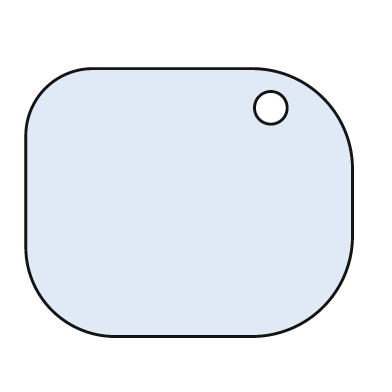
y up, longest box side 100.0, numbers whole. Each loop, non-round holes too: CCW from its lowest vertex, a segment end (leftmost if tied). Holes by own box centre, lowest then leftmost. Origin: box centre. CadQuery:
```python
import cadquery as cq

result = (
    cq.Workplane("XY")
    .moveTo(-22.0, -41.0)
    .lineTo(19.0, -41.0)
    .threePointArc((41.0, -32.0), (50.0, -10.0))
    .lineTo(50.0, 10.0)
    .threePointArc((41.0, 32.0), (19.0, 41.0))
    .lineTo(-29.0, 41.0)
    .threePointArc((-44.0, 35.0), (-50.0, 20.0))
    .lineTo(-50.0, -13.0)
    .threePointArc((-42.0, -33.0), (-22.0, -41.0))
    .close()
    .moveTo(25.0, 29.0)
    .circle(5.0)
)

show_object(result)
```